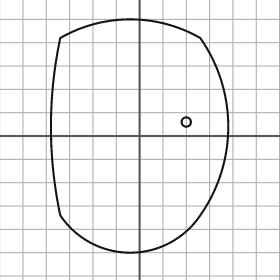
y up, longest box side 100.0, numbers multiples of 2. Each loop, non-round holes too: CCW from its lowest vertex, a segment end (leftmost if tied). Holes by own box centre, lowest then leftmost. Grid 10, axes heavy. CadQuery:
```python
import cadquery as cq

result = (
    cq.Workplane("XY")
    .moveTo(-34.0, -34.0)
    .threePointArc((-4.0, -50.0), (26.0, -34.0))
    .threePointArc((38.0, 4.0), (26.0, 42.0))
    .threePointArc((-4.0, 50.0), (-34.0, 42.0))
    .threePointArc((-38.0, 4.0), (-34.0, -34.0))
    .close()
    .moveTo(20.0, 6.0)
    .circle(2.0)
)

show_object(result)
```